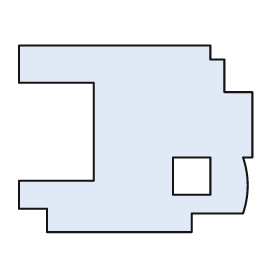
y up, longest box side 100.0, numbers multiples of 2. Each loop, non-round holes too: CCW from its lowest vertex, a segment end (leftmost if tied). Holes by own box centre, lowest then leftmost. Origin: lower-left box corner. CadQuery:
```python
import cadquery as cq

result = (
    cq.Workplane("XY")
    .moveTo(12.0, 0.0)
    .lineTo(74.0, 0.0)
    .lineTo(74.0, 8.0)
    .lineTo(96.0, 8.0)
    .threePointArc((98.0, 20.0), (96.0, 32.0))
    .lineTo(100.0, 32.0)
    .lineTo(100.0, 60.0)
    .lineTo(88.0, 60.0)
    .lineTo(88.0, 74.0)
    .lineTo(82.0, 74.0)
    .lineTo(82.0, 80.0)
    .lineTo(0.0, 80.0)
    .lineTo(0.0, 64.0)
    .lineTo(32.0, 64.0)
    .lineTo(32.0, 22.0)
    .lineTo(0.0, 22.0)
    .lineTo(0.0, 10.0)
    .lineTo(12.0, 10.0)
    .close()
    .moveTo(66.0, 16.0)
    .lineTo(82.0, 16.0)
    .lineTo(82.0, 32.0)
    .lineTo(66.0, 32.0)
    .close()
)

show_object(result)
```